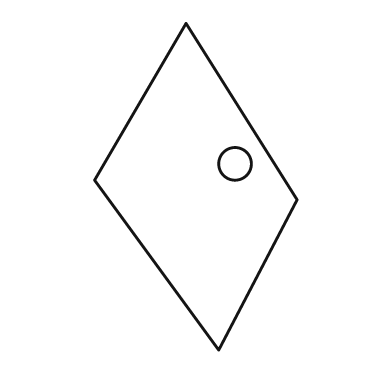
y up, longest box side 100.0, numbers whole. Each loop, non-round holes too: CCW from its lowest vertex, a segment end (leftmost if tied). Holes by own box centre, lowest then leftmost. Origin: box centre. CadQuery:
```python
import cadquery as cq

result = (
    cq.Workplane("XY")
    .moveTo(7.0, -50.0)
    .lineTo(31.0, -4.0)
    .lineTo(-3.0, 50.0)
    .lineTo(-31.0, 2.0)
    .close()
    .moveTo(12.0, 7.0)
    .circle(5.0)
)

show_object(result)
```